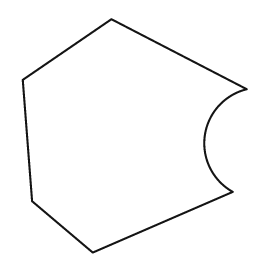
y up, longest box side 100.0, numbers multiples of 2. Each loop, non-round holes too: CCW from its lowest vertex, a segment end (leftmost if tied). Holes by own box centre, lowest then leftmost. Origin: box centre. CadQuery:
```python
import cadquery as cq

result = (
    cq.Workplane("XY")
    .moveTo(-18.0, -50.0)
    .lineTo(42.0, -24.0)
    .threePointArc((30.0, 0.0), (48.0, 20.0))
    .lineTo(-10.0, 50.0)
    .lineTo(-48.0, 24.0)
    .lineTo(-44.0, -28.0)
    .close()
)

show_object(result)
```